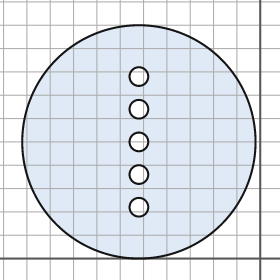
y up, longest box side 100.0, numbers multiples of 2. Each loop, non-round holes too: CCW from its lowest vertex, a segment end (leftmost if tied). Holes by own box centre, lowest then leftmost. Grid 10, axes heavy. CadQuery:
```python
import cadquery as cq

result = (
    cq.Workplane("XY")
    .moveTo(-52.0, 50.0)
    .circle(50.0)
    .moveTo(-52.0, 22.0)
    .circle(4.0)
    .moveTo(-52.0, 36.0)
    .circle(4.0)
    .moveTo(-52.0, 50.0)
    .circle(4.0)
    .moveTo(-52.0, 64.0)
    .circle(4.0)
    .moveTo(-52.0, 78.0)
    .circle(4.0)
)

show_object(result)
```